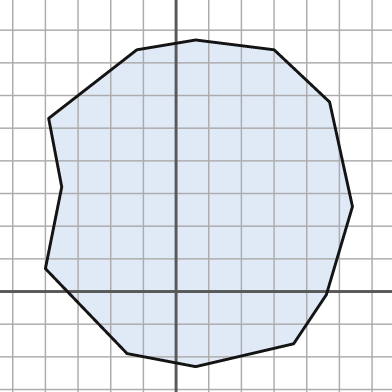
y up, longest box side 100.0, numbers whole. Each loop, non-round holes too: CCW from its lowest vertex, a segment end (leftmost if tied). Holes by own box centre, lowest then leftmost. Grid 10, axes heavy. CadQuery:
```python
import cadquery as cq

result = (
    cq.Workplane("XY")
    .moveTo(6.0, -23.0)
    .lineTo(36.0, -16.0)
    .lineTo(46.0, -1.0)
    .lineTo(54.0, 26.0)
    .lineTo(47.0, 58.0)
    .lineTo(30.0, 74.0)
    .lineTo(6.0, 77.0)
    .lineTo(-12.0, 74.0)
    .lineTo(-39.0, 53.0)
    .lineTo(-35.0, 32.0)
    .lineTo(-40.0, 7.0)
    .lineTo(-15.0, -19.0)
    .close()
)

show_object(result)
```